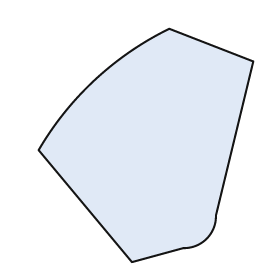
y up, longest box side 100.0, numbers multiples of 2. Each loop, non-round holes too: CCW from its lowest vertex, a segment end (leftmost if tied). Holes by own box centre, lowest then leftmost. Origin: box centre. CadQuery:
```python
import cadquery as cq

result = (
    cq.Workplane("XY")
    .moveTo(-6.0, -50.0)
    .lineTo(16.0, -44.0)
    .threePointArc((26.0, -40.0), (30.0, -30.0))
    .lineTo(46.0, 36.0)
    .lineTo(10.0, 50.0)
    .threePointArc((-22.0, 28.0), (-46.0, -2.0))
    .close()
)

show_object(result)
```